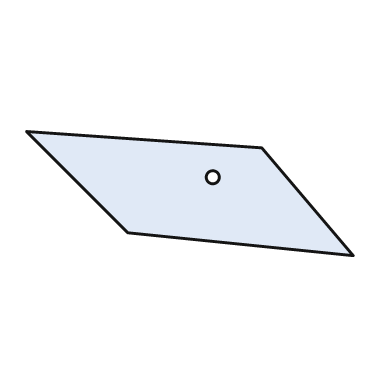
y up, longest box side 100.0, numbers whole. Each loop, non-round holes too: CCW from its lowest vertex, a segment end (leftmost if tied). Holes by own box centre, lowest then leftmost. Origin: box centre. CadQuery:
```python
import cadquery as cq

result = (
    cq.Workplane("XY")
    .moveTo(50.0, -19.0)
    .lineTo(22.0, 14.0)
    .lineTo(-50.0, 19.0)
    .lineTo(-19.0, -12.0)
    .close()
    .moveTo(7.0, 5.0)
    .circle(2.0)
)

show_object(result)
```